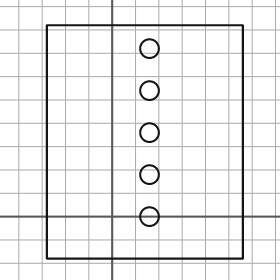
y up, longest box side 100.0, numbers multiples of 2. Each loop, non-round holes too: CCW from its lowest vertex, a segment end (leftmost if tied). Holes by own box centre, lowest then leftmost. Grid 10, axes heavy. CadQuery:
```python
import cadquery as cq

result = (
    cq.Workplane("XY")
    .moveTo(-28.0, -18.0)
    .lineTo(56.0, -18.0)
    .lineTo(56.0, 82.0)
    .lineTo(-28.0, 82.0)
    .close()
    .moveTo(16.0, 0.0)
    .circle(4.0)
    .moveTo(16.0, 18.0)
    .circle(4.0)
    .moveTo(16.0, 36.0)
    .circle(4.0)
    .moveTo(16.0, 54.0)
    .circle(4.0)
    .moveTo(16.0, 72.0)
    .circle(4.0)
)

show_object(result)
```